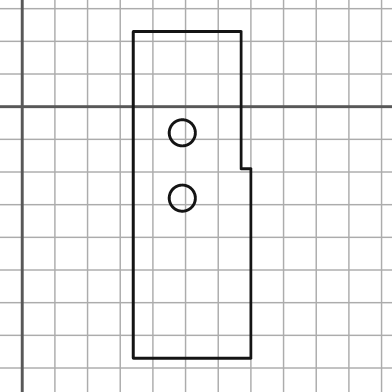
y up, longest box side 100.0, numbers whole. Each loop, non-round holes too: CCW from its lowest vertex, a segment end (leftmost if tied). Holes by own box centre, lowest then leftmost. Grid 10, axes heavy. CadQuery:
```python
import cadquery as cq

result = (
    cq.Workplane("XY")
    .moveTo(34.0, -77.0)
    .lineTo(70.0, -77.0)
    .lineTo(70.0, -19.0)
    .lineTo(67.0, -19.0)
    .lineTo(67.0, 23.0)
    .lineTo(34.0, 23.0)
    .close()
    .moveTo(49.0, -28.0)
    .circle(4.0)
    .moveTo(49.0, -8.0)
    .circle(4.0)
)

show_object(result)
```